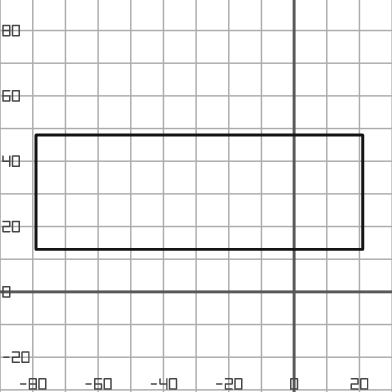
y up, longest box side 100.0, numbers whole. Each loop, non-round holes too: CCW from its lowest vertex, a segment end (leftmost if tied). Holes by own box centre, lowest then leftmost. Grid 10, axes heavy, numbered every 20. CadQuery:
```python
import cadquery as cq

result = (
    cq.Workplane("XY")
    .moveTo(-79.0, 13.0)
    .lineTo(21.0, 13.0)
    .lineTo(21.0, 48.0)
    .lineTo(-79.0, 48.0)
    .close()
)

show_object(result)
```